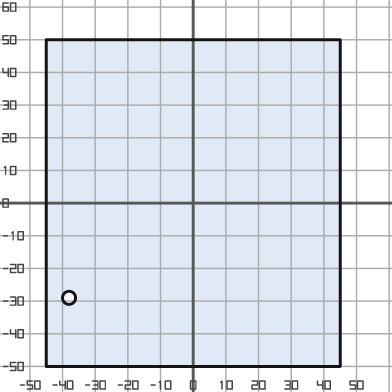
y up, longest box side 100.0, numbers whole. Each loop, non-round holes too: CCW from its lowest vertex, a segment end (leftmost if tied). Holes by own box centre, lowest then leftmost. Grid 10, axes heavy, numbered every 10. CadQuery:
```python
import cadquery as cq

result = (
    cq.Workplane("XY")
    .moveTo(-45.0, -50.0)
    .lineTo(45.0, -50.0)
    .lineTo(45.0, 50.0)
    .lineTo(-45.0, 50.0)
    .close()
    .moveTo(-38.0, -29.0)
    .circle(2.0)
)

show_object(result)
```